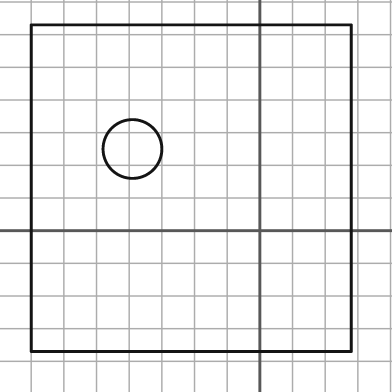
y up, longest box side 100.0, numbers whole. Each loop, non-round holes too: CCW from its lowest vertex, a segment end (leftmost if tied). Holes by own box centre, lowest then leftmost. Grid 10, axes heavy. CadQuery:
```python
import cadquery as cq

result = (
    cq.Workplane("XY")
    .moveTo(-70.0, -37.0)
    .lineTo(28.0, -37.0)
    .lineTo(28.0, 63.0)
    .lineTo(-70.0, 63.0)
    .close()
    .moveTo(-39.0, 25.0)
    .circle(9.0)
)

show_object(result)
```